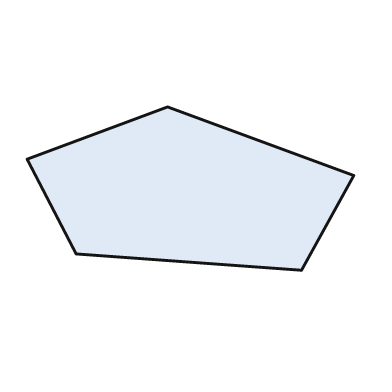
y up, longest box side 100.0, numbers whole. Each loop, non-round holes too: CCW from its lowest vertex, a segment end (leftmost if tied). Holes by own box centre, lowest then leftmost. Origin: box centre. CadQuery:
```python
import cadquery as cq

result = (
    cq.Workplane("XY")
    .moveTo(34.0, -25.0)
    .lineTo(50.0, 4.0)
    .lineTo(-7.0, 25.0)
    .lineTo(-50.0, 9.0)
    .lineTo(-35.0, -20.0)
    .close()
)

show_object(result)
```